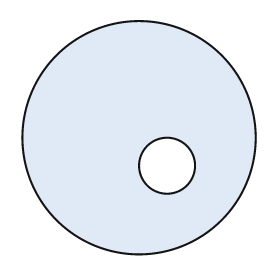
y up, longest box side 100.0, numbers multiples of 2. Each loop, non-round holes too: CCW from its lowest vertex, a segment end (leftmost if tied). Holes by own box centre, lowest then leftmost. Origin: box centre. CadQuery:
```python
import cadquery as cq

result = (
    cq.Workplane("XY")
    .moveTo(0.0, 0.0)
    .circle(50.0)
    .moveTo(12.0, -12.0)
    .circle(12.0)
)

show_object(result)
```